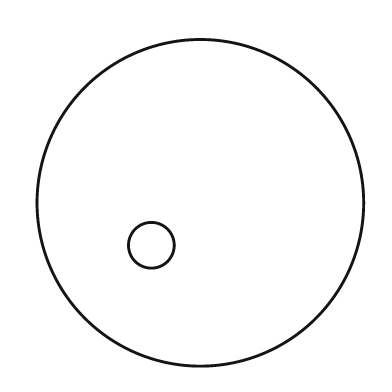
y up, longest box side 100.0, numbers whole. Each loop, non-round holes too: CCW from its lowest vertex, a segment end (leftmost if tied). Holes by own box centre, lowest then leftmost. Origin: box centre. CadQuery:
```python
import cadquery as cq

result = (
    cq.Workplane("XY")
    .moveTo(0.0, 0.0)
    .circle(50.0)
    .moveTo(-15.0, -13.0)
    .circle(7.0)
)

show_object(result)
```